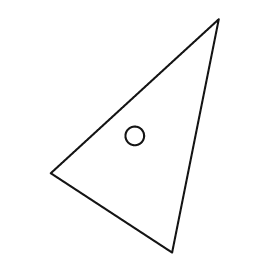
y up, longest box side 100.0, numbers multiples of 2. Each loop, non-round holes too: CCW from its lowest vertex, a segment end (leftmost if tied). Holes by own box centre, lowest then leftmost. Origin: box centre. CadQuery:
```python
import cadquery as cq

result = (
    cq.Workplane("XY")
    .moveTo(16.0, -50.0)
    .lineTo(36.0, 50.0)
    .lineTo(-36.0, -16.0)
    .close()
    .moveTo(0.0, 0.0)
    .circle(4.0)
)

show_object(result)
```